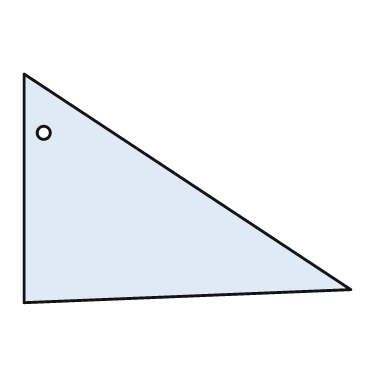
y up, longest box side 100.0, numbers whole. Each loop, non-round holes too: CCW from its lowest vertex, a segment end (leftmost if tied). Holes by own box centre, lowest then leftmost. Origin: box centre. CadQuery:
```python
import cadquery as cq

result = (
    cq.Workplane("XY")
    .moveTo(-50.0, -35.0)
    .lineTo(50.0, -31.0)
    .lineTo(-50.0, 35.0)
    .close()
    .moveTo(-44.0, 17.0)
    .circle(2.0)
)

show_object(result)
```